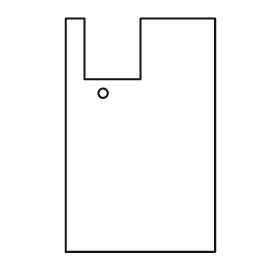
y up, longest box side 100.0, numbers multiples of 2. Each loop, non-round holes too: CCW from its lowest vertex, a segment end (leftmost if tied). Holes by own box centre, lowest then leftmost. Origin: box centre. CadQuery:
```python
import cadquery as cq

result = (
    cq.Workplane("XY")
    .moveTo(-32.0, -50.0)
    .lineTo(32.0, -50.0)
    .lineTo(32.0, 50.0)
    .lineTo(0.0, 50.0)
    .lineTo(0.0, 24.0)
    .lineTo(-24.0, 24.0)
    .lineTo(-24.0, 50.0)
    .lineTo(-32.0, 50.0)
    .close()
    .moveTo(-16.0, 18.0)
    .circle(2.0)
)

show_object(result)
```